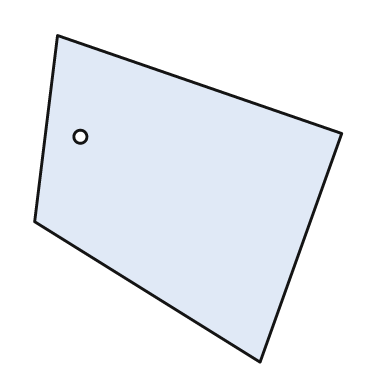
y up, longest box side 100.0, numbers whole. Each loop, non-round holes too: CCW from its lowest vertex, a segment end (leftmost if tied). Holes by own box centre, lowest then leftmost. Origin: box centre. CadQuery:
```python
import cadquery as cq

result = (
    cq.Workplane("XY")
    .moveTo(22.0, -50.0)
    .lineTo(47.0, 20.0)
    .lineTo(-40.0, 50.0)
    .lineTo(-47.0, -7.0)
    .close()
    .moveTo(-33.0, 19.0)
    .circle(2.0)
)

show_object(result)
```